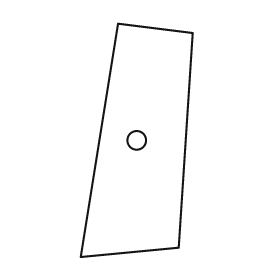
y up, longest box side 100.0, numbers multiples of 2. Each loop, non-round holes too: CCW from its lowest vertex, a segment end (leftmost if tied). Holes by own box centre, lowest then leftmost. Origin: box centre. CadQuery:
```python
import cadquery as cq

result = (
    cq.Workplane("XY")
    .moveTo(-24.0, -50.0)
    .lineTo(18.0, -46.0)
    .lineTo(24.0, 46.0)
    .lineTo(-8.0, 50.0)
    .close()
    .moveTo(0.0, 0.0)
    .circle(4.0)
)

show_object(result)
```